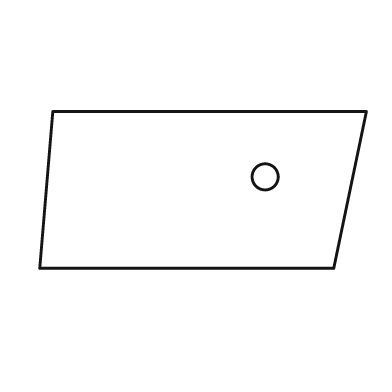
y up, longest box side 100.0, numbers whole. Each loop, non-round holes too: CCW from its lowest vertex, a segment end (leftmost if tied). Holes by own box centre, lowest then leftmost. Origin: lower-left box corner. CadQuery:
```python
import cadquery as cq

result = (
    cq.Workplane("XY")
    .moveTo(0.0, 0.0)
    .lineTo(90.0, 0.0)
    .lineTo(100.0, 48.0)
    .lineTo(4.0, 48.0)
    .close()
    .moveTo(69.0, 28.0)
    .circle(4.0)
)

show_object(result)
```